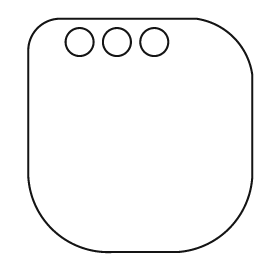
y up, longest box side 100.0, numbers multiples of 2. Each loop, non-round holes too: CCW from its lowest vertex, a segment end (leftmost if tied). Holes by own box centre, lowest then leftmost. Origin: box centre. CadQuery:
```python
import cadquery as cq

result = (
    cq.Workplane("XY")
    .moveTo(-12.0, -50.0)
    .lineTo(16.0, -50.0)
    .threePointArc((38.0, -40.0), (48.0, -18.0))
    .lineTo(48.0, 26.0)
    .threePointArc((40.0, 42.0), (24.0, 50.0))
    .lineTo(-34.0, 50.0)
    .threePointArc((-44.0, 46.0), (-48.0, 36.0))
    .lineTo(-48.0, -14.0)
    .threePointArc((-38.0, -40.0), (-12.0, -50.0))
    .close()
    .moveTo(-26.0, 40.0)
    .circle(6.0)
    .moveTo(-10.0, 40.0)
    .circle(6.0)
    .moveTo(6.0, 40.0)
    .circle(6.0)
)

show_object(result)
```